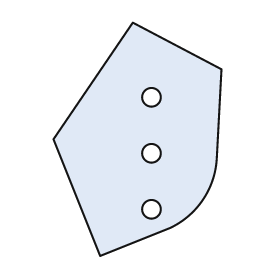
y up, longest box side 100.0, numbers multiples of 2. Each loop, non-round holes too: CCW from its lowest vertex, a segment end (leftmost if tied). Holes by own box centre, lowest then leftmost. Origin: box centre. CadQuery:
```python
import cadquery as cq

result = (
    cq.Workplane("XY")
    .moveTo(-16.0, -50.0)
    .lineTo(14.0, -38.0)
    .threePointArc((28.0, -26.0), (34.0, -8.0))
    .lineTo(36.0, 30.0)
    .lineTo(-2.0, 50.0)
    .lineTo(-36.0, 0.0)
    .close()
    .moveTo(6.0, -30.0)
    .circle(4.0)
    .moveTo(6.0, -6.0)
    .circle(4.0)
    .moveTo(6.0, 18.0)
    .circle(4.0)
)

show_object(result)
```